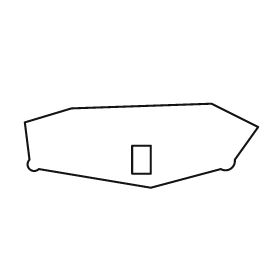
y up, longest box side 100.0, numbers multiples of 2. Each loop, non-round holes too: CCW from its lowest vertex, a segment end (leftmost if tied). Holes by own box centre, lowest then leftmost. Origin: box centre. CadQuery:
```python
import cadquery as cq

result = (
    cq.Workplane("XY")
    .moveTo(4.0, -18.0)
    .lineTo(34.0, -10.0)
    .threePointArc((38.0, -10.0), (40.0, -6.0))
    .lineTo(50.0, 8.0)
    .lineTo(30.0, 18.0)
    .lineTo(-30.0, 16.0)
    .lineTo(-50.0, 10.0)
    .lineTo(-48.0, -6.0)
    .threePointArc((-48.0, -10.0), (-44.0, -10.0))
    .close()
    .moveTo(-4.0, -12.0)
    .lineTo(4.0, -12.0)
    .lineTo(4.0, 0.0)
    .lineTo(-4.0, 0.0)
    .close()
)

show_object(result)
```